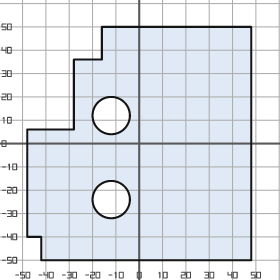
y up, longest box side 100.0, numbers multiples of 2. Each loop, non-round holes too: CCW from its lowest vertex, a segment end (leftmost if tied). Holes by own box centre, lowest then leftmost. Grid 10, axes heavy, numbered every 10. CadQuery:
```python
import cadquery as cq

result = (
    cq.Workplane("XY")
    .moveTo(-42.0, -50.0)
    .lineTo(48.0, -50.0)
    .lineTo(48.0, 50.0)
    .lineTo(-16.0, 50.0)
    .lineTo(-16.0, 36.0)
    .lineTo(-28.0, 36.0)
    .lineTo(-28.0, 6.0)
    .lineTo(-48.0, 6.0)
    .lineTo(-48.0, -40.0)
    .lineTo(-42.0, -40.0)
    .close()
    .moveTo(-12.0, -24.0)
    .circle(8.0)
    .moveTo(-12.0, 12.0)
    .circle(8.0)
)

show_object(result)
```